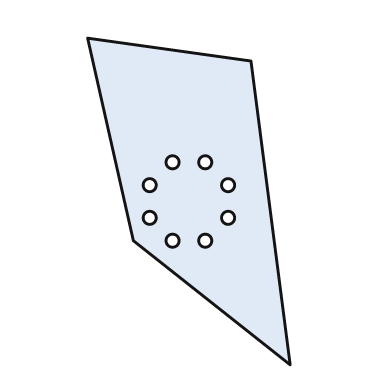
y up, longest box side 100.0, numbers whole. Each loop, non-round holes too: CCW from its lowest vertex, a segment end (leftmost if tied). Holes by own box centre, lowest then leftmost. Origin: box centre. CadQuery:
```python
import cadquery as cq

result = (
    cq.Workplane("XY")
    .moveTo(31.0, -50.0)
    .lineTo(19.0, 43.0)
    .lineTo(-31.0, 50.0)
    .lineTo(-17.0, -12.0)
    .close()
    .moveTo(-5.0, -12.0)
    .circle(2.0)
    .moveTo(5.0, -12.0)
    .circle(2.0)
    .moveTo(-12.0, -5.0)
    .circle(2.0)
    .moveTo(12.0, -5.0)
    .circle(2.0)
    .moveTo(-12.0, 5.0)
    .circle(2.0)
    .moveTo(12.0, 5.0)
    .circle(2.0)
    .moveTo(-5.0, 12.0)
    .circle(2.0)
    .moveTo(5.0, 12.0)
    .circle(2.0)
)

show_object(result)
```